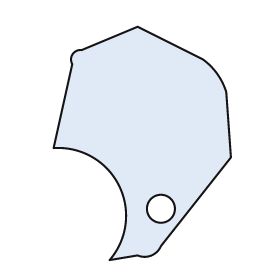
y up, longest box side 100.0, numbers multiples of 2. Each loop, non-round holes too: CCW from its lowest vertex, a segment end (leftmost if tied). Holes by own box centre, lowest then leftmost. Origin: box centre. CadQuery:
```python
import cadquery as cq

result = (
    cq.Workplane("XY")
    .moveTo(-14.0, -50.0)
    .lineTo(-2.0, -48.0)
    .threePointArc((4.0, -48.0), (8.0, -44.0))
    .lineTo(38.0, -6.0)
    .lineTo(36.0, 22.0)
    .threePointArc((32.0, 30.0), (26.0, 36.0))
    .lineTo(-2.0, 50.0)
    .lineTo(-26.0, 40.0)
    .threePointArc((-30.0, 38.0), (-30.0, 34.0))
    .lineTo(-38.0, -2.0)
    .threePointArc((-10.0, -18.0), (-14.0, -50.0))
    .close()
    .moveTo(8.0, -28.0)
    .circle(6.0)
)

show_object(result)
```